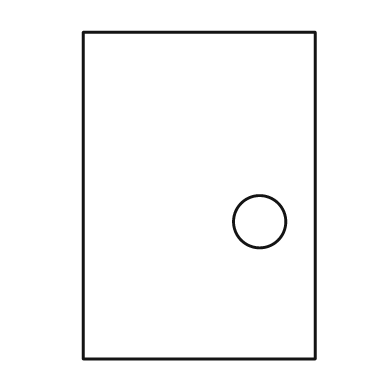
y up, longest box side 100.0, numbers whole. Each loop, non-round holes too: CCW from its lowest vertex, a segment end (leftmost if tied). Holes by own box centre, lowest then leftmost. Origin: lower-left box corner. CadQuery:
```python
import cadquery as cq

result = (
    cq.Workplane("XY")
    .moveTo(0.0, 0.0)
    .lineTo(71.0, 0.0)
    .lineTo(71.0, 100.0)
    .lineTo(0.0, 100.0)
    .close()
    .moveTo(54.0, 42.0)
    .circle(8.0)
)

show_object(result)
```